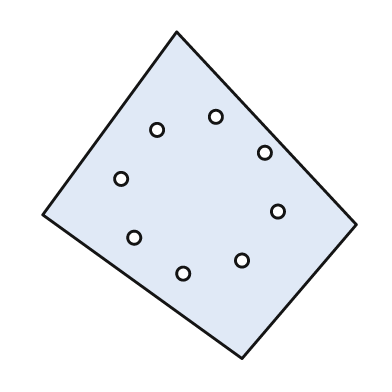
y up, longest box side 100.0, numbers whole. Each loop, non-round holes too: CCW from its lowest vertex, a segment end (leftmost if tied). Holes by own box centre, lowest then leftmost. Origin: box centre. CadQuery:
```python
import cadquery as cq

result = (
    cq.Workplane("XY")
    .moveTo(13.0, -50.0)
    .lineTo(48.0, -9.0)
    .lineTo(-7.0, 50.0)
    .lineTo(-48.0, -6.0)
    .close()
    .moveTo(-5.0, -24.0)
    .circle(2.0)
    .moveTo(13.0, -20.0)
    .circle(2.0)
    .moveTo(-20.0, -13.0)
    .circle(2.0)
    .moveTo(24.0, -5.0)
    .circle(2.0)
    .moveTo(-24.0, 5.0)
    .circle(2.0)
    .moveTo(20.0, 13.0)
    .circle(2.0)
    .moveTo(-13.0, 20.0)
    .circle(2.0)
    .moveTo(5.0, 24.0)
    .circle(2.0)
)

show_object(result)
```